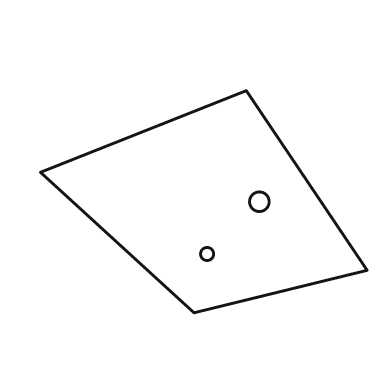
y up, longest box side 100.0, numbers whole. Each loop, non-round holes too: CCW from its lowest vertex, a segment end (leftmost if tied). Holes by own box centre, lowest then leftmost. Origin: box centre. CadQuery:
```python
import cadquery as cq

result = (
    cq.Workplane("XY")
    .moveTo(-3.0, -34.0)
    .lineTo(50.0, -21.0)
    .lineTo(13.0, 34.0)
    .lineTo(-50.0, 9.0)
    .close()
    .moveTo(1.0, -16.0)
    .circle(2.0)
    .moveTo(17.0, 0.0)
    .circle(3.0)
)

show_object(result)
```